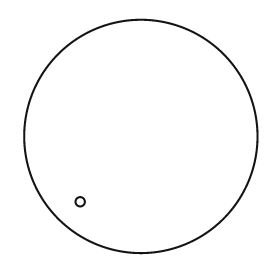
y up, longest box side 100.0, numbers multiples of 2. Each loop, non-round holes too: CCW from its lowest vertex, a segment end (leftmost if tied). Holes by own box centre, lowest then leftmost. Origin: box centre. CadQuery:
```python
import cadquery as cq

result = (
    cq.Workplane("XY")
    .moveTo(0.0, 0.0)
    .circle(50.0)
    .moveTo(-26.0, -28.0)
    .circle(2.0)
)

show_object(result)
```